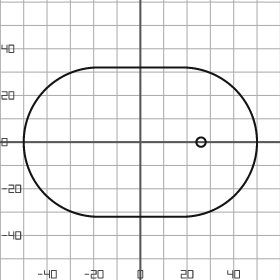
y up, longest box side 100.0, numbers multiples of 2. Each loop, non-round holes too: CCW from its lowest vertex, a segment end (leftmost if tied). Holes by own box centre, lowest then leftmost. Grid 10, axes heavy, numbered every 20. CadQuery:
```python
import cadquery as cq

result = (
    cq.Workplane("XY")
    .moveTo(-18.0, -32.0)
    .lineTo(18.0, -32.0)
    .threePointArc((50.0, 0.0), (18.0, 32.0))
    .lineTo(-18.0, 32.0)
    .threePointArc((-50.0, 0.0), (-18.0, -32.0))
    .close()
    .moveTo(26.0, 0.0)
    .circle(2.0)
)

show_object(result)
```